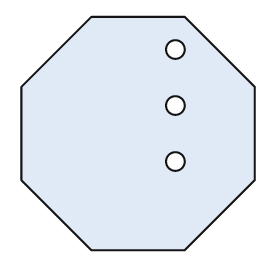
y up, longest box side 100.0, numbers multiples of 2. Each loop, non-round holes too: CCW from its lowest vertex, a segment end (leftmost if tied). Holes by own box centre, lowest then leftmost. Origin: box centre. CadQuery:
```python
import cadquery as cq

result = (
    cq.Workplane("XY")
    .moveTo(-20.0, -50.0)
    .lineTo(20.0, -50.0)
    .lineTo(50.0, -20.0)
    .lineTo(50.0, 20.0)
    .lineTo(20.0, 50.0)
    .lineTo(-20.0, 50.0)
    .lineTo(-50.0, 20.0)
    .lineTo(-50.0, -20.0)
    .close()
    .moveTo(16.0, -12.0)
    .circle(4.0)
    .moveTo(16.0, 12.0)
    .circle(4.0)
    .moveTo(16.0, 36.0)
    .circle(4.0)
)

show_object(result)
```